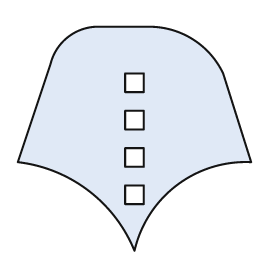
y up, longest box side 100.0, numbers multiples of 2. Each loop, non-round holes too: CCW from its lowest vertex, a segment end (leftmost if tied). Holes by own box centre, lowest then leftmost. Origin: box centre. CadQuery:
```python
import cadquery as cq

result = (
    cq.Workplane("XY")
    .moveTo(0.0, -48.0)
    .threePointArc((18.0, -20.0), (50.0, -10.0))
    .lineTo(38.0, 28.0)
    .threePointArc((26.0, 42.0), (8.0, 48.0))
    .lineTo(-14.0, 48.0)
    .threePointArc((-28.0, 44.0), (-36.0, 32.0))
    .lineTo(-50.0, -10.0)
    .threePointArc((-20.0, -22.0), (0.0, -48.0))
    .close()
    .moveTo(-4.0, -28.0)
    .lineTo(4.0, -28.0)
    .lineTo(4.0, -20.0)
    .lineTo(-4.0, -20.0)
    .close()
    .moveTo(-4.0, -12.0)
    .lineTo(4.0, -12.0)
    .lineTo(4.0, -4.0)
    .lineTo(-4.0, -4.0)
    .close()
    .moveTo(-4.0, 4.0)
    .lineTo(4.0, 4.0)
    .lineTo(4.0, 12.0)
    .lineTo(-4.0, 12.0)
    .close()
    .moveTo(-4.0, 20.0)
    .lineTo(4.0, 20.0)
    .lineTo(4.0, 28.0)
    .lineTo(-4.0, 28.0)
    .close()
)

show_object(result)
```